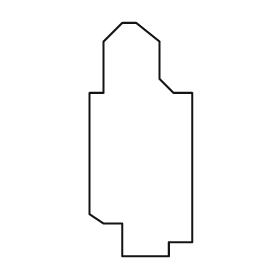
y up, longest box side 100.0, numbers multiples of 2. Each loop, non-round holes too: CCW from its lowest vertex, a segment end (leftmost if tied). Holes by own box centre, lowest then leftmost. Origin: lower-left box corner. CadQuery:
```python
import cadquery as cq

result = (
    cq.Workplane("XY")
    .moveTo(14.0, 0.0)
    .lineTo(34.0, 0.0)
    .lineTo(34.0, 6.0)
    .lineTo(44.0, 6.0)
    .lineTo(44.0, 70.0)
    .lineTo(36.0, 70.0)
    .lineTo(30.0, 76.0)
    .lineTo(30.0, 92.0)
    .lineTo(20.0, 100.0)
    .lineTo(14.0, 100.0)
    .lineTo(6.0, 92.0)
    .lineTo(6.0, 70.0)
    .lineTo(0.0, 70.0)
    .lineTo(0.0, 18.0)
    .lineTo(6.0, 14.0)
    .lineTo(14.0, 14.0)
    .close()
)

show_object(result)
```